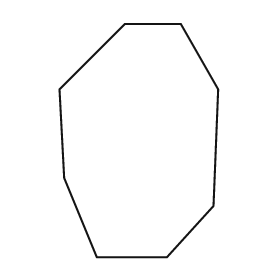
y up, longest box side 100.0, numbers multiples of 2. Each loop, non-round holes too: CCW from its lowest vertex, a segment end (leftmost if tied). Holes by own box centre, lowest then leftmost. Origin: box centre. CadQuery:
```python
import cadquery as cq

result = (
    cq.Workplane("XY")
    .moveTo(-18.0, -50.0)
    .lineTo(12.0, -50.0)
    .lineTo(32.0, -28.0)
    .lineTo(34.0, 22.0)
    .lineTo(18.0, 50.0)
    .lineTo(-6.0, 50.0)
    .lineTo(-34.0, 22.0)
    .lineTo(-32.0, -16.0)
    .close()
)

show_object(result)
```